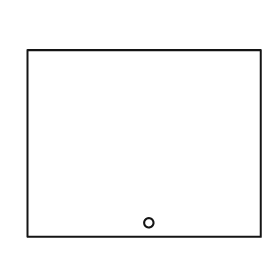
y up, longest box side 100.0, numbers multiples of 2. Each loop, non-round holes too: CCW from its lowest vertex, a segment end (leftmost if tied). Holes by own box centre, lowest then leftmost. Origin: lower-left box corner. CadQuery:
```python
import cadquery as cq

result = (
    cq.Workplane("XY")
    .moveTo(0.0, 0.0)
    .lineTo(100.0, 0.0)
    .lineTo(100.0, 80.0)
    .lineTo(0.0, 80.0)
    .close()
    .moveTo(52.0, 6.0)
    .circle(2.0)
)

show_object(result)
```